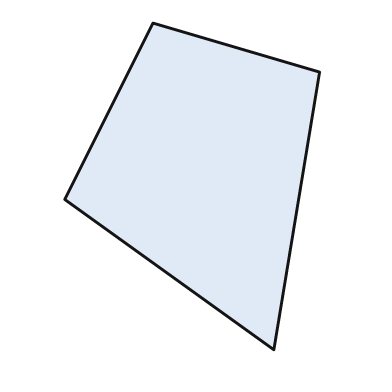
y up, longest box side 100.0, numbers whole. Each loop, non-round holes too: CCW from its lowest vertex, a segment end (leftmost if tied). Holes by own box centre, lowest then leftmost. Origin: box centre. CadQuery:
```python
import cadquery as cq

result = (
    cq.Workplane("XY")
    .moveTo(25.0, -50.0)
    .lineTo(39.0, 35.0)
    .lineTo(-12.0, 50.0)
    .lineTo(-39.0, -4.0)
    .close()
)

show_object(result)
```